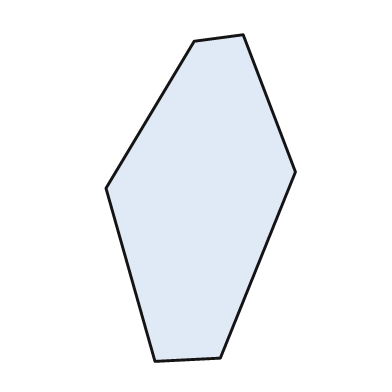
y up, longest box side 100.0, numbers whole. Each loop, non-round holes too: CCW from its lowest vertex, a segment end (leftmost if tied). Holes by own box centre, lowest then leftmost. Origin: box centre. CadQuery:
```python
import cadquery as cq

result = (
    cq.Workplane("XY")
    .moveTo(-14.0, -50.0)
    .lineTo(6.0, -49.0)
    .lineTo(29.0, 8.0)
    .lineTo(13.0, 50.0)
    .lineTo(-2.0, 48.0)
    .lineTo(-29.0, 3.0)
    .close()
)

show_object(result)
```